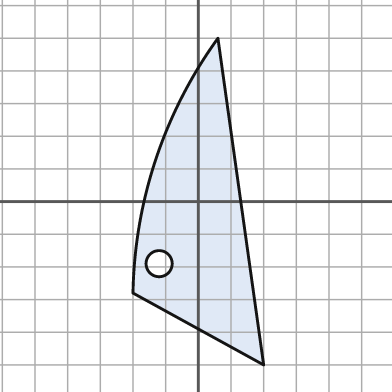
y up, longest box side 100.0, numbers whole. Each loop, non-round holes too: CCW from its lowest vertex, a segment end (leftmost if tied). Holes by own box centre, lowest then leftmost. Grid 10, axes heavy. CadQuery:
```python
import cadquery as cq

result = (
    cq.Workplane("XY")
    .moveTo(20.0, -50.0)
    .lineTo(6.0, 50.0)
    .threePointArc((-13.0, 13.0), (-20.0, -28.0))
    .close()
    .moveTo(-12.0, -19.0)
    .circle(4.0)
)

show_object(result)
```